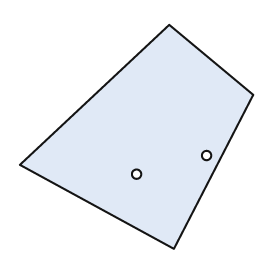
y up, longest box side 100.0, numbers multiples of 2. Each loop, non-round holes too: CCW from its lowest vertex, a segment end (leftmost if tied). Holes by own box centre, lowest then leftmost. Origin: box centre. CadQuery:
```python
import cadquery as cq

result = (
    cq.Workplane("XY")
    .moveTo(16.0, -48.0)
    .lineTo(50.0, 18.0)
    .lineTo(14.0, 48.0)
    .lineTo(-50.0, -12.0)
    .close()
    .moveTo(0.0, -16.0)
    .circle(2.0)
    .moveTo(30.0, -8.0)
    .circle(2.0)
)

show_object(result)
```